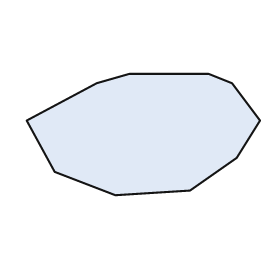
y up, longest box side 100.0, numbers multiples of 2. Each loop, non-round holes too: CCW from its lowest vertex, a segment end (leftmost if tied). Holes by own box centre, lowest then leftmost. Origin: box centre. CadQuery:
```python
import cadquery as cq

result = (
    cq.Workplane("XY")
    .moveTo(-12.0, -26.0)
    .lineTo(20.0, -24.0)
    .lineTo(40.0, -10.0)
    .lineTo(50.0, 6.0)
    .lineTo(38.0, 22.0)
    .lineTo(28.0, 26.0)
    .lineTo(-6.0, 26.0)
    .lineTo(-20.0, 22.0)
    .lineTo(-50.0, 6.0)
    .lineTo(-38.0, -16.0)
    .close()
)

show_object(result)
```